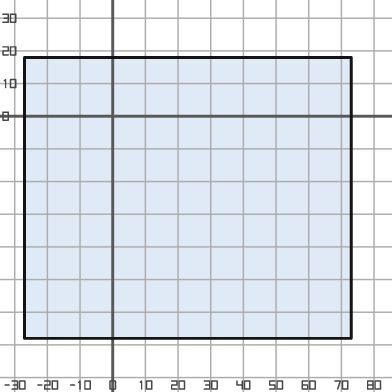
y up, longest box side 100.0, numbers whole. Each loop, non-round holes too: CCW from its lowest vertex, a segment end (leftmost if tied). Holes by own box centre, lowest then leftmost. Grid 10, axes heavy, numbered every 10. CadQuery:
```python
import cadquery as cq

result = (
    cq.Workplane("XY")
    .moveTo(-27.0, -68.0)
    .lineTo(73.0, -68.0)
    .lineTo(73.0, 18.0)
    .lineTo(-27.0, 18.0)
    .close()
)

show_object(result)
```